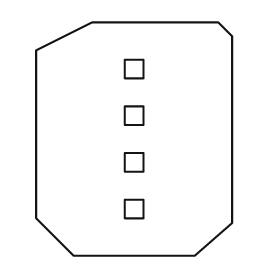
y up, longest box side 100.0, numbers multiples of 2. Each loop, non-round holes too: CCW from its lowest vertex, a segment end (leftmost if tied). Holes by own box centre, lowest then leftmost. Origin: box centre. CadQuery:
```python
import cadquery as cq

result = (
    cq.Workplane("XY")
    .moveTo(-26.0, -50.0)
    .lineTo(26.0, -50.0)
    .lineTo(42.0, -36.0)
    .lineTo(42.0, 44.0)
    .lineTo(36.0, 50.0)
    .lineTo(-18.0, 50.0)
    .lineTo(-42.0, 38.0)
    .lineTo(-42.0, -34.0)
    .close()
    .moveTo(-4.0, -34.0)
    .lineTo(4.0, -34.0)
    .lineTo(4.0, -26.0)
    .lineTo(-4.0, -26.0)
    .close()
    .moveTo(-4.0, -14.0)
    .lineTo(4.0, -14.0)
    .lineTo(4.0, -6.0)
    .lineTo(-4.0, -6.0)
    .close()
    .moveTo(-4.0, 6.0)
    .lineTo(4.0, 6.0)
    .lineTo(4.0, 14.0)
    .lineTo(-4.0, 14.0)
    .close()
    .moveTo(-4.0, 26.0)
    .lineTo(4.0, 26.0)
    .lineTo(4.0, 34.0)
    .lineTo(-4.0, 34.0)
    .close()
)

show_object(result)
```